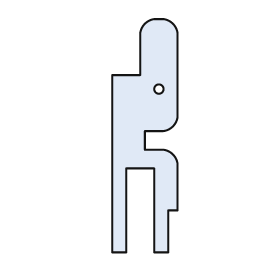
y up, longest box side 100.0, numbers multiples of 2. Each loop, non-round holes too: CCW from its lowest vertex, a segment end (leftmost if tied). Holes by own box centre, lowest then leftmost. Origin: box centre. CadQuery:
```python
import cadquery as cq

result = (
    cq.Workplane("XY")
    .moveTo(-14.0, -50.0)
    .lineTo(-8.0, -50.0)
    .lineTo(-8.0, -14.0)
    .lineTo(4.0, -14.0)
    .lineTo(4.0, -50.0)
    .lineTo(10.0, -50.0)
    .lineTo(10.0, -32.0)
    .lineTo(14.0, -32.0)
    .lineTo(14.0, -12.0)
    .threePointArc((12.0, -8.0), (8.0, -6.0))
    .lineTo(0.0, -6.0)
    .lineTo(0.0, 2.0)
    .lineTo(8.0, 2.0)
    .threePointArc((12.0, 4.0), (14.0, 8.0))
    .lineTo(14.0, 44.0)
    .threePointArc((12.0, 48.0), (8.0, 50.0))
    .lineTo(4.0, 50.0)
    .threePointArc((0.0, 48.0), (-2.0, 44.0))
    .lineTo(-2.0, 26.0)
    .lineTo(-14.0, 26.0)
    .close()
    .moveTo(6.0, 20.0)
    .circle(2.0)
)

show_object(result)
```